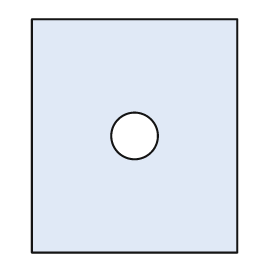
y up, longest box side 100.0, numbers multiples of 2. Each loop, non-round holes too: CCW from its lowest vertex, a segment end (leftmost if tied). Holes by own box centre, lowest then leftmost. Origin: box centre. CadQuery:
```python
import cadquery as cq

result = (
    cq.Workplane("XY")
    .moveTo(-44.0, -50.0)
    .lineTo(44.0, -50.0)
    .lineTo(44.0, 50.0)
    .lineTo(-44.0, 50.0)
    .close()
    .moveTo(0.0, 0.0)
    .circle(10.0)
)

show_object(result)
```